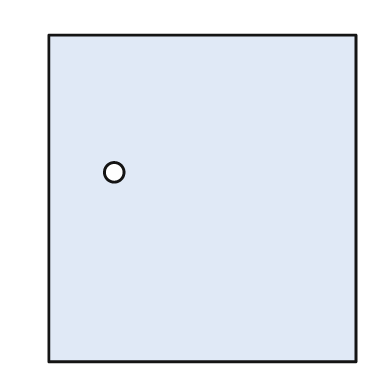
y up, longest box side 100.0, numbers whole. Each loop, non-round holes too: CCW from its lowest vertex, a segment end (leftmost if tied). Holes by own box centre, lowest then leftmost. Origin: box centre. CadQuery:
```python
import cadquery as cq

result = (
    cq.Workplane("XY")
    .moveTo(-47.0, -50.0)
    .lineTo(47.0, -50.0)
    .lineTo(47.0, 50.0)
    .lineTo(-47.0, 50.0)
    .close()
    .moveTo(-27.0, 8.0)
    .circle(3.0)
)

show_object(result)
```